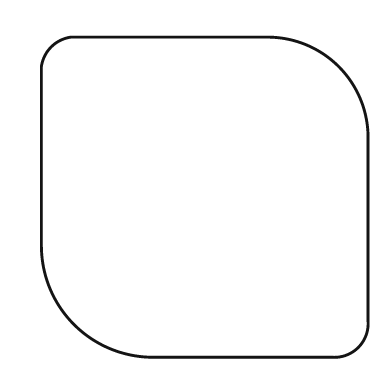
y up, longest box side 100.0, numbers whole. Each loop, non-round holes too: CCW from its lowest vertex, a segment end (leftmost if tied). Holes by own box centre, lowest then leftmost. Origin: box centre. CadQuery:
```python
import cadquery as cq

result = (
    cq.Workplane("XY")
    .moveTo(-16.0, -49.0)
    .lineTo(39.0, -49.0)
    .threePointArc((47.0, -46.0), (50.0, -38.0))
    .lineTo(50.0, 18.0)
    .threePointArc((41.0, 40.0), (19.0, 49.0))
    .lineTo(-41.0, 49.0)
    .threePointArc((-47.0, 46.0), (-50.0, 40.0))
    .lineTo(-50.0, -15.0)
    .threePointArc((-40.0, -39.0), (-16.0, -49.0))
    .close()
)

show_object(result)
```